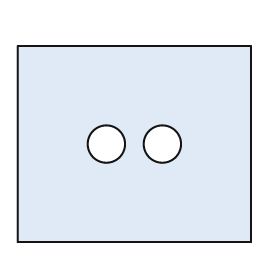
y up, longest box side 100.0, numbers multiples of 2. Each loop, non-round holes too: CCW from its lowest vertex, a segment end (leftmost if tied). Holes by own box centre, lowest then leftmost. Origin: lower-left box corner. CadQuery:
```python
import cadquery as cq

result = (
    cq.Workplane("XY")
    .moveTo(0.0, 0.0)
    .lineTo(100.0, 0.0)
    .lineTo(100.0, 84.0)
    .lineTo(0.0, 84.0)
    .close()
    .moveTo(38.0, 42.0)
    .circle(8.0)
    .moveTo(62.0, 42.0)
    .circle(8.0)
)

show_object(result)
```